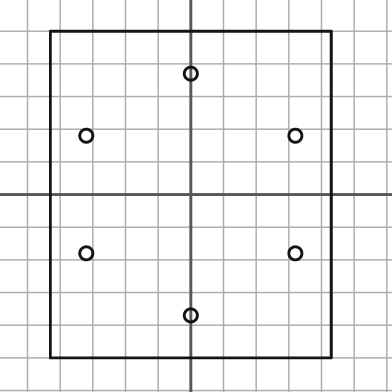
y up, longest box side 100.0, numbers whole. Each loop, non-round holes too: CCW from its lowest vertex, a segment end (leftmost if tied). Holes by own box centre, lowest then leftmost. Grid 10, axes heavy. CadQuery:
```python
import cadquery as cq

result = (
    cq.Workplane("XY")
    .moveTo(-43.0, -50.0)
    .lineTo(43.0, -50.0)
    .lineTo(43.0, 50.0)
    .lineTo(-43.0, 50.0)
    .close()
    .moveTo(0.0, -37.0)
    .circle(2.0)
    .moveTo(-32.0, -18.0)
    .circle(2.0)
    .moveTo(32.0, -18.0)
    .circle(2.0)
    .moveTo(-32.0, 18.0)
    .circle(2.0)
    .moveTo(32.0, 18.0)
    .circle(2.0)
    .moveTo(0.0, 37.0)
    .circle(2.0)
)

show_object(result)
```